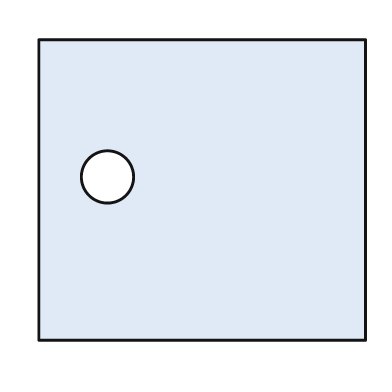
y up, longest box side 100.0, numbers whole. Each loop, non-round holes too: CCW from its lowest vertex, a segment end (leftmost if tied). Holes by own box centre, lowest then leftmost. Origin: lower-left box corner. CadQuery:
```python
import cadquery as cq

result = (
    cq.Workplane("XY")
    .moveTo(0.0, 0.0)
    .lineTo(100.0, 0.0)
    .lineTo(100.0, 92.0)
    .lineTo(0.0, 92.0)
    .close()
    .moveTo(21.0, 50.0)
    .circle(8.0)
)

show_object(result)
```